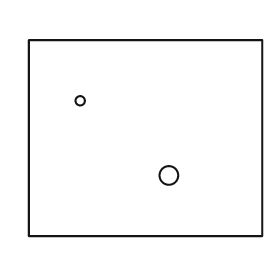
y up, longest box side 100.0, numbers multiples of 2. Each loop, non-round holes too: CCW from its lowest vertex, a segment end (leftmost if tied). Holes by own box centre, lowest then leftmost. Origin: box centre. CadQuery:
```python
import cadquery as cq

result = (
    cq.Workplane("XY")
    .moveTo(-50.0, -42.0)
    .lineTo(50.0, -42.0)
    .lineTo(50.0, 42.0)
    .lineTo(-50.0, 42.0)
    .close()
    .moveTo(10.0, -16.0)
    .circle(4.0)
    .moveTo(-28.0, 16.0)
    .circle(2.0)
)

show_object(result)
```